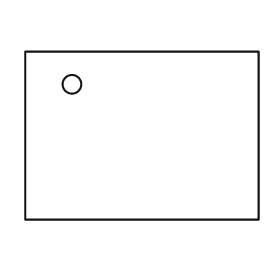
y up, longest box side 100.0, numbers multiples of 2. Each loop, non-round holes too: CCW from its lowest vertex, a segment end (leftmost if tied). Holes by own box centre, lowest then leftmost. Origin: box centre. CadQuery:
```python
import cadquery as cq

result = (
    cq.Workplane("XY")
    .moveTo(-50.0, -36.0)
    .lineTo(50.0, -36.0)
    .lineTo(50.0, 36.0)
    .lineTo(-50.0, 36.0)
    .close()
    .moveTo(-30.0, 22.0)
    .circle(4.0)
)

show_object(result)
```